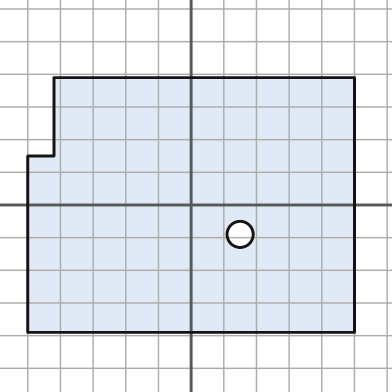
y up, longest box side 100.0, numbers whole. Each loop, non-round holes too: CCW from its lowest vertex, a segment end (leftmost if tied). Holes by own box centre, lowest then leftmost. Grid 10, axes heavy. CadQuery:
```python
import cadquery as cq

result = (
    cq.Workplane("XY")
    .moveTo(-50.0, -39.0)
    .lineTo(50.0, -39.0)
    .lineTo(50.0, 39.0)
    .lineTo(-42.0, 39.0)
    .lineTo(-42.0, 15.0)
    .lineTo(-50.0, 15.0)
    .close()
    .moveTo(15.0, -9.0)
    .circle(4.0)
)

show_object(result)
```